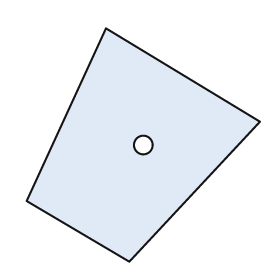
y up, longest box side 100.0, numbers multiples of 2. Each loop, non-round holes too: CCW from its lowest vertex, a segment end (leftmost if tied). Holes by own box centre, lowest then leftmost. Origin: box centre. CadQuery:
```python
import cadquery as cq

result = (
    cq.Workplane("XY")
    .moveTo(-6.0, -50.0)
    .lineTo(50.0, 10.0)
    .lineTo(-16.0, 50.0)
    .lineTo(-50.0, -24.0)
    .close()
    .moveTo(0.0, 0.0)
    .circle(4.0)
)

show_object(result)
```